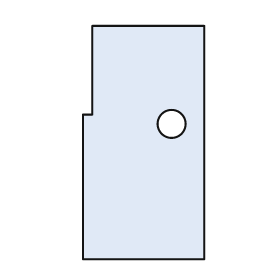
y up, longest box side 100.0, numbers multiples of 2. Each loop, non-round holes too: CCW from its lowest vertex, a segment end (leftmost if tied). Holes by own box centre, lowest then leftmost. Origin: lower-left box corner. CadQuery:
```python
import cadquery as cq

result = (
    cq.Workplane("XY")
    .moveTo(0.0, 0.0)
    .lineTo(52.0, 0.0)
    .lineTo(52.0, 100.0)
    .lineTo(4.0, 100.0)
    .lineTo(4.0, 62.0)
    .lineTo(0.0, 62.0)
    .close()
    .moveTo(38.0, 58.0)
    .circle(6.0)
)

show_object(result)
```